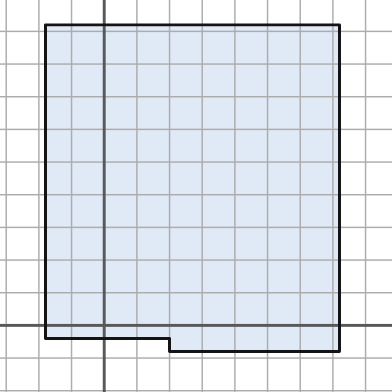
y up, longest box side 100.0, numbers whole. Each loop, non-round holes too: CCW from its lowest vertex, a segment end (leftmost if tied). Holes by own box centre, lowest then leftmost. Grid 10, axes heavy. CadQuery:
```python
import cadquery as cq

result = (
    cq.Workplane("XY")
    .moveTo(20.0, -8.0)
    .lineTo(72.0, -8.0)
    .lineTo(72.0, 92.0)
    .lineTo(-18.0, 92.0)
    .lineTo(-18.0, -4.0)
    .lineTo(20.0, -4.0)
    .close()
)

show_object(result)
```